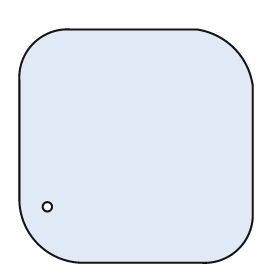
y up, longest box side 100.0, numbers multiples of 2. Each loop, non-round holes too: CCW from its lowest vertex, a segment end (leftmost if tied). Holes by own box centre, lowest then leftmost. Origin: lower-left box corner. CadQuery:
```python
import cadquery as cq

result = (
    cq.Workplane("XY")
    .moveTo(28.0, 0.0)
    .lineTo(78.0, 0.0)
    .threePointArc((94.0, 6.0), (100.0, 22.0))
    .lineTo(100.0, 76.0)
    .threePointArc((92.0, 92.0), (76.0, 100.0))
    .lineTo(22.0, 100.0)
    .threePointArc((6.0, 94.0), (0.0, 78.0))
    .lineTo(0.0, 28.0)
    .threePointArc((8.0, 8.0), (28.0, 0.0))
    .close()
    .moveTo(12.0, 24.0)
    .circle(2.0)
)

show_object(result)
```